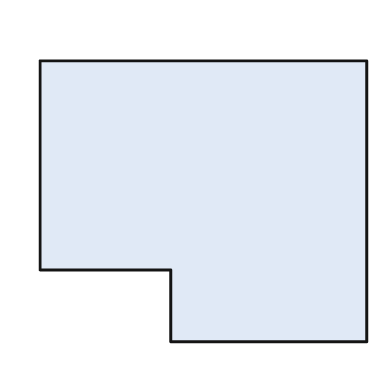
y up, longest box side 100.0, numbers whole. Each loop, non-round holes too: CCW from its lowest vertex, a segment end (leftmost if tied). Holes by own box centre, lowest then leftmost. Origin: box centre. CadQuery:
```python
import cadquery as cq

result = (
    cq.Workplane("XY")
    .moveTo(-10.0, -43.0)
    .lineTo(50.0, -43.0)
    .lineTo(50.0, 43.0)
    .lineTo(-50.0, 43.0)
    .lineTo(-50.0, -21.0)
    .lineTo(-10.0, -21.0)
    .close()
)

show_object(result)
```